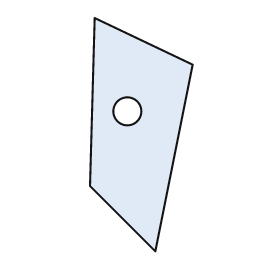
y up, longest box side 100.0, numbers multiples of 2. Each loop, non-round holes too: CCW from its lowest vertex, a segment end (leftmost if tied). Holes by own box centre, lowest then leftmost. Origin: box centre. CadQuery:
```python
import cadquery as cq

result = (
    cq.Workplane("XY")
    .moveTo(6.0, -50.0)
    .lineTo(22.0, 30.0)
    .lineTo(-20.0, 50.0)
    .lineTo(-22.0, -22.0)
    .close()
    .moveTo(-6.0, 10.0)
    .circle(6.0)
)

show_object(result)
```